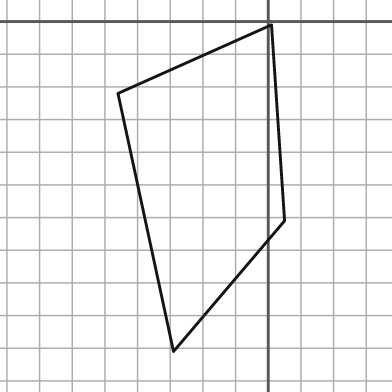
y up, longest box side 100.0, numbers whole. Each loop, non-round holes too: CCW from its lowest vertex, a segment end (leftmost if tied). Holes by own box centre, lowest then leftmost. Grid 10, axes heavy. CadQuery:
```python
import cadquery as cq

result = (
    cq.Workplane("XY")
    .moveTo(-29.0, -101.0)
    .lineTo(5.0, -61.0)
    .lineTo(1.0, -1.0)
    .lineTo(-46.0, -22.0)
    .close()
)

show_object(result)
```